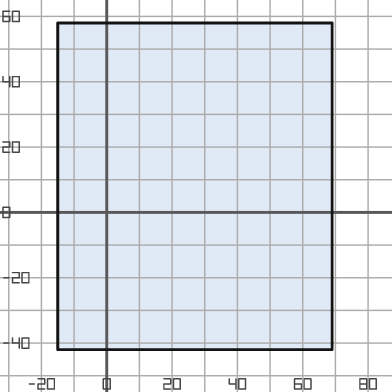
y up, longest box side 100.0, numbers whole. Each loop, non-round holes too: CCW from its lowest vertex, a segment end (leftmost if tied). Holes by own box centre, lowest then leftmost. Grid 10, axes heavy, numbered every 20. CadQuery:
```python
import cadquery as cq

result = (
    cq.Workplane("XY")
    .moveTo(-15.0, -42.0)
    .lineTo(69.0, -42.0)
    .lineTo(69.0, 58.0)
    .lineTo(-15.0, 58.0)
    .close()
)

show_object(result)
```